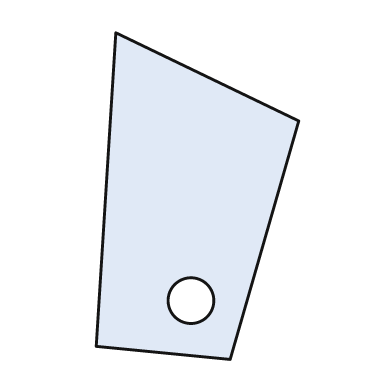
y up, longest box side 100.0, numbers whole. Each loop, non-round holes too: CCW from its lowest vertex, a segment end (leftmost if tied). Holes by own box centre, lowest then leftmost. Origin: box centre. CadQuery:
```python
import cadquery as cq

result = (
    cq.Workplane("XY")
    .moveTo(10.0, -50.0)
    .lineTo(31.0, 23.0)
    .lineTo(-25.0, 50.0)
    .lineTo(-31.0, -46.0)
    .close()
    .moveTo(-2.0, -32.0)
    .circle(7.0)
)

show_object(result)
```